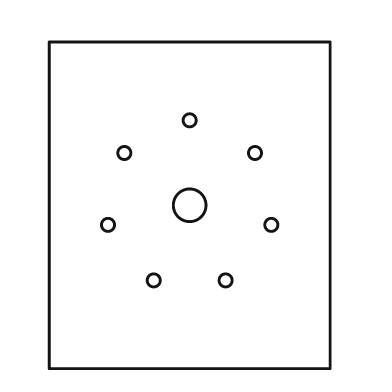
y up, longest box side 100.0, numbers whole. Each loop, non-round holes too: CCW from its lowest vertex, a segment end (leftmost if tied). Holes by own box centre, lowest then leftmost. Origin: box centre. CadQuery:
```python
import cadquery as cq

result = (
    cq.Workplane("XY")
    .moveTo(-43.0, -50.0)
    .lineTo(43.0, -50.0)
    .lineTo(43.0, 50.0)
    .lineTo(-43.0, 50.0)
    .close()
    .moveTo(-11.0, -23.0)
    .circle(2.0)
    .moveTo(11.0, -23.0)
    .circle(2.0)
    .moveTo(-25.0, -6.0)
    .circle(2.0)
    .moveTo(25.0, -6.0)
    .circle(2.0)
    .moveTo(0.0, 0.0)
    .circle(5.0)
    .moveTo(-20.0, 16.0)
    .circle(2.0)
    .moveTo(20.0, 16.0)
    .circle(2.0)
    .moveTo(0.0, 26.0)
    .circle(2.0)
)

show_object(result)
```